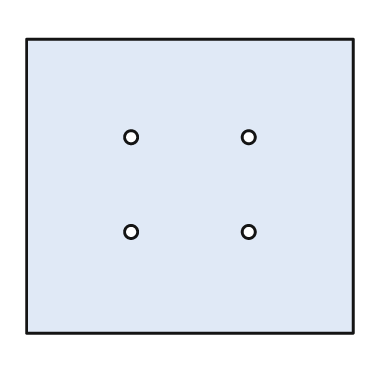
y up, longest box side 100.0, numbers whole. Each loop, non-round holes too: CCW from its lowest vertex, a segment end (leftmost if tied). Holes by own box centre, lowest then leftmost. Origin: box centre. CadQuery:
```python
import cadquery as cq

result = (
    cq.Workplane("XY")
    .moveTo(-50.0, -45.0)
    .lineTo(50.0, -45.0)
    .lineTo(50.0, 45.0)
    .lineTo(-50.0, 45.0)
    .close()
    .moveTo(-18.0, -14.0)
    .circle(2.0)
    .moveTo(18.0, -14.0)
    .circle(2.0)
    .moveTo(-18.0, 15.0)
    .circle(2.0)
    .moveTo(18.0, 15.0)
    .circle(2.0)
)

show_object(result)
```